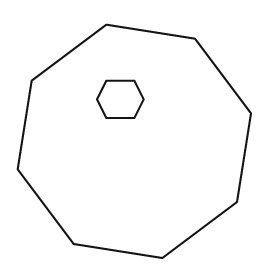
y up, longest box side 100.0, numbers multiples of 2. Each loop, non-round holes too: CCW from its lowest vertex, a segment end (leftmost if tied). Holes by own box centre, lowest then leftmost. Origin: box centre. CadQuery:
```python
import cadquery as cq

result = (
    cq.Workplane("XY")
    .moveTo(12.0, -50.0)
    .lineTo(44.0, -26.0)
    .lineTo(50.0, 12.0)
    .lineTo(26.0, 44.0)
    .lineTo(-12.0, 50.0)
    .lineTo(-44.0, 26.0)
    .lineTo(-50.0, -12.0)
    .lineTo(-26.0, -44.0)
    .close()
    .moveTo(-12.0, 10.0)
    .lineTo(0.0, 10.0)
    .lineTo(4.0, 18.0)
    .lineTo(0.0, 26.0)
    .lineTo(-12.0, 26.0)
    .lineTo(-16.0, 18.0)
    .close()
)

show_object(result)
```